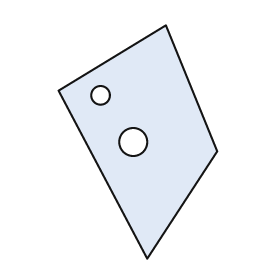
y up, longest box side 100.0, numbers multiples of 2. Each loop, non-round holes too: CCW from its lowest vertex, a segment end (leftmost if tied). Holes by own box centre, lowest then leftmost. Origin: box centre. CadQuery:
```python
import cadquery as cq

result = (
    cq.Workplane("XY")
    .moveTo(4.0, -50.0)
    .lineTo(34.0, -4.0)
    .lineTo(12.0, 50.0)
    .lineTo(-34.0, 22.0)
    .close()
    .moveTo(-2.0, 0.0)
    .circle(6.0)
    .moveTo(-16.0, 20.0)
    .circle(4.0)
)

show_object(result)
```